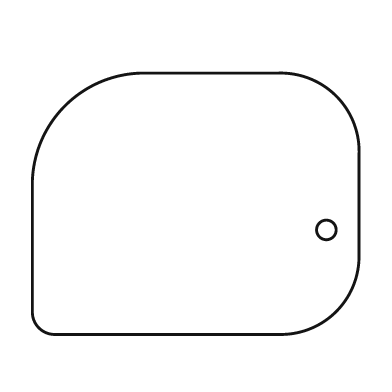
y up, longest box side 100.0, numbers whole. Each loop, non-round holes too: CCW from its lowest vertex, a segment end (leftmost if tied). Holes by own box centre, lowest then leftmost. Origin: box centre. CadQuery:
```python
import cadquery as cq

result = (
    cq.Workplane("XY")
    .moveTo(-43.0, -40.0)
    .lineTo(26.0, -40.0)
    .threePointArc((43.0, -33.0), (50.0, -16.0))
    .lineTo(50.0, 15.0)
    .threePointArc((43.0, 33.0), (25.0, 40.0))
    .lineTo(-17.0, 40.0)
    .threePointArc((-40.0, 30.0), (-50.0, 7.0))
    .lineTo(-50.0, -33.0)
    .threePointArc((-48.0, -38.0), (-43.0, -40.0))
    .close()
    .moveTo(40.0, -8.0)
    .circle(3.0)
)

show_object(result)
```